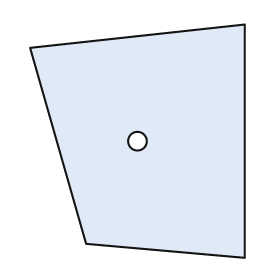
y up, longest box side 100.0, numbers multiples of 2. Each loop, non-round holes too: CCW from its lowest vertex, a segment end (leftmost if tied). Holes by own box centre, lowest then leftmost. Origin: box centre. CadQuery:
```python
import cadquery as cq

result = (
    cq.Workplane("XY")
    .moveTo(46.0, -50.0)
    .lineTo(46.0, 50.0)
    .lineTo(-46.0, 40.0)
    .lineTo(-22.0, -44.0)
    .close()
    .moveTo(0.0, 0.0)
    .circle(4.0)
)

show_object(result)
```